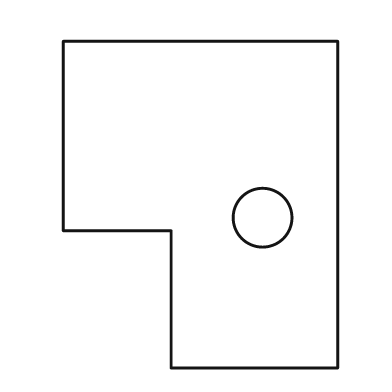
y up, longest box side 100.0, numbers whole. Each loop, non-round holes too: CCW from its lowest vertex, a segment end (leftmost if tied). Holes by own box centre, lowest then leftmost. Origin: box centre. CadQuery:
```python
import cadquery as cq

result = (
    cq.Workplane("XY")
    .moveTo(-9.0, -50.0)
    .lineTo(42.0, -50.0)
    .lineTo(42.0, 50.0)
    .lineTo(-42.0, 50.0)
    .lineTo(-42.0, -8.0)
    .lineTo(-9.0, -8.0)
    .close()
    .moveTo(19.0, -4.0)
    .circle(9.0)
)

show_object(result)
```